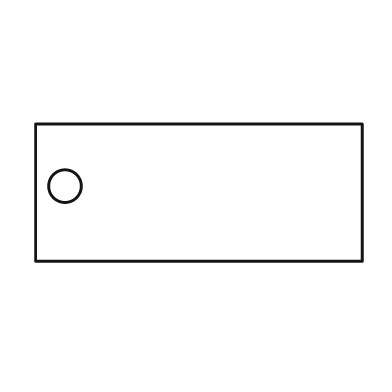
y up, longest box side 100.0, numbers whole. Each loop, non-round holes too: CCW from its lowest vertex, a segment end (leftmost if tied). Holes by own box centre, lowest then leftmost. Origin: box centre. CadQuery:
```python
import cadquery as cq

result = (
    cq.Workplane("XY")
    .moveTo(-50.0, -21.0)
    .lineTo(50.0, -21.0)
    .lineTo(50.0, 21.0)
    .lineTo(-50.0, 21.0)
    .close()
    .moveTo(-41.0, 2.0)
    .circle(5.0)
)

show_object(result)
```